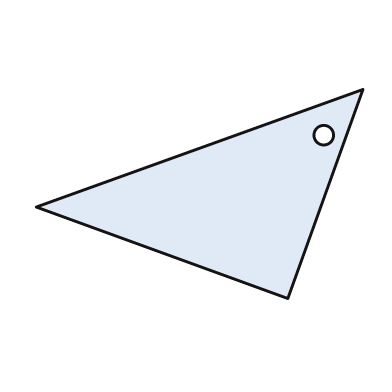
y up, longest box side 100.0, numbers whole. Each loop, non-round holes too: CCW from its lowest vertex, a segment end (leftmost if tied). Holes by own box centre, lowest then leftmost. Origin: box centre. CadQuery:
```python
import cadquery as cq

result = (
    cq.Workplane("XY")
    .moveTo(27.0, -32.0)
    .lineTo(50.0, 32.0)
    .lineTo(-50.0, -4.0)
    .close()
    .moveTo(38.0, 18.0)
    .circle(3.0)
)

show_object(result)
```